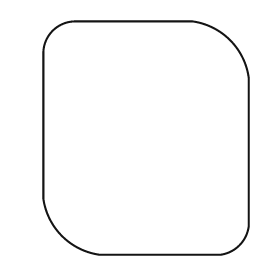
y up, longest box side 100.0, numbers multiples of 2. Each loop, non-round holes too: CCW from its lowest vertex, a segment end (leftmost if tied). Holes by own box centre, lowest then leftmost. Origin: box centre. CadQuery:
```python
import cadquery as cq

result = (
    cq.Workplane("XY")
    .moveTo(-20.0, -50.0)
    .lineTo(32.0, -50.0)
    .threePointArc((40.0, -46.0), (44.0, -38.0))
    .lineTo(44.0, 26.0)
    .threePointArc((36.0, 42.0), (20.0, 50.0))
    .lineTo(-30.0, 50.0)
    .threePointArc((-40.0, 46.0), (-44.0, 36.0))
    .lineTo(-44.0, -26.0)
    .threePointArc((-36.0, -42.0), (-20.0, -50.0))
    .close()
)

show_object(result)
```